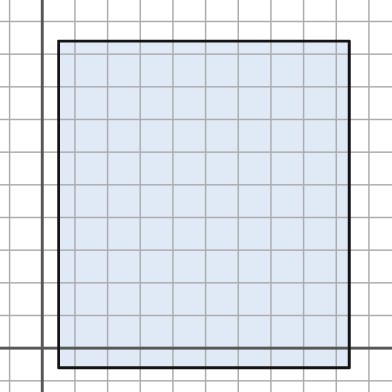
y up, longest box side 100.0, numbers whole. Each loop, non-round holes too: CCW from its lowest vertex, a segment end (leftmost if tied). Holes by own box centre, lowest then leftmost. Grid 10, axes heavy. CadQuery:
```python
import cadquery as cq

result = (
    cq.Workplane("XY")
    .moveTo(5.0, -6.0)
    .lineTo(94.0, -6.0)
    .lineTo(94.0, 94.0)
    .lineTo(5.0, 94.0)
    .close()
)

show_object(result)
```